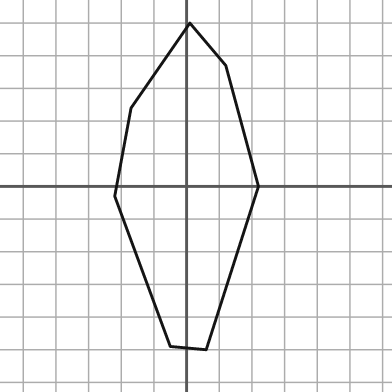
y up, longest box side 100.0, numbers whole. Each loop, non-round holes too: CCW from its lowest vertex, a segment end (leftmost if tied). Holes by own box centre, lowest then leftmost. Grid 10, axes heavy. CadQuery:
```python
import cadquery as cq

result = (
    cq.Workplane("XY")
    .moveTo(6.0, -50.0)
    .lineTo(22.0, 0.0)
    .lineTo(12.0, 37.0)
    .lineTo(1.0, 50.0)
    .lineTo(-17.0, 24.0)
    .lineTo(-22.0, -3.0)
    .lineTo(-5.0, -49.0)
    .close()
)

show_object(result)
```